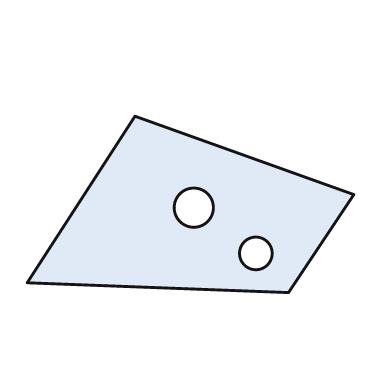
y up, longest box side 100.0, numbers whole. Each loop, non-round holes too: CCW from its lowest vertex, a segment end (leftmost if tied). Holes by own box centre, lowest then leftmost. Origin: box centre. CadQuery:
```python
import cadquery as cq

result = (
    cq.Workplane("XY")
    .moveTo(30.0, -27.0)
    .lineTo(50.0, 3.0)
    .lineTo(-17.0, 27.0)
    .lineTo(-50.0, -24.0)
    .close()
    .moveTo(20.0, -15.0)
    .circle(5.0)
    .moveTo(1.0, -1.0)
    .circle(6.0)
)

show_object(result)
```